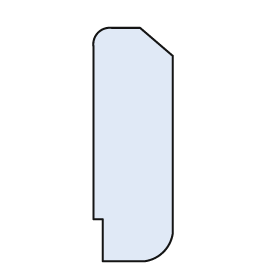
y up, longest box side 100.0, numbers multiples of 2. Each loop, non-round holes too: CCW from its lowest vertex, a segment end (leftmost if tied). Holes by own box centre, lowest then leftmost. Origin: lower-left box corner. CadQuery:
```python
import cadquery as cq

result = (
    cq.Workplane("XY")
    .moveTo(4.0, 0.0)
    .lineTo(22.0, 0.0)
    .threePointArc((30.0, 4.0), (34.0, 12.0))
    .lineTo(34.0, 88.0)
    .lineTo(20.0, 100.0)
    .lineTo(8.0, 100.0)
    .threePointArc((2.0, 98.0), (0.0, 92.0))
    .lineTo(0.0, 18.0)
    .lineTo(4.0, 18.0)
    .close()
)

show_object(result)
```